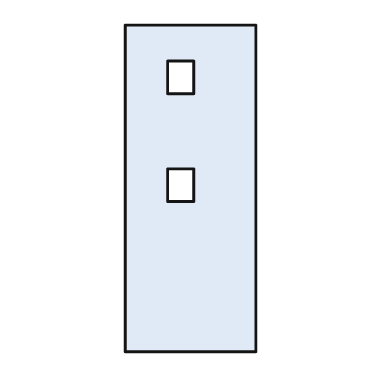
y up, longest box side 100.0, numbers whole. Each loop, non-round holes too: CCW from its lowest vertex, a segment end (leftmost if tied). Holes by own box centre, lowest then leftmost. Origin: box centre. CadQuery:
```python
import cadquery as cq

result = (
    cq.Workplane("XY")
    .moveTo(-20.0, -50.0)
    .lineTo(20.0, -50.0)
    .lineTo(20.0, 50.0)
    .lineTo(-20.0, 50.0)
    .close()
    .moveTo(-7.0, -4.0)
    .lineTo(1.0, -4.0)
    .lineTo(1.0, 6.0)
    .lineTo(-7.0, 6.0)
    .close()
    .moveTo(-7.0, 29.0)
    .lineTo(1.0, 29.0)
    .lineTo(1.0, 39.0)
    .lineTo(-7.0, 39.0)
    .close()
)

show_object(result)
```